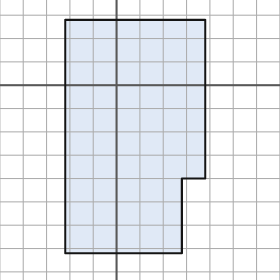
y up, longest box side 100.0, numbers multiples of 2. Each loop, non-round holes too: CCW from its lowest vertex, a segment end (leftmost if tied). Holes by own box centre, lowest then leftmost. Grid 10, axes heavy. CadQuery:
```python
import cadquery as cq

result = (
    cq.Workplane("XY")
    .moveTo(-22.0, -72.0)
    .lineTo(28.0, -72.0)
    .lineTo(28.0, -40.0)
    .lineTo(38.0, -40.0)
    .lineTo(38.0, 28.0)
    .lineTo(-22.0, 28.0)
    .close()
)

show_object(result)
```